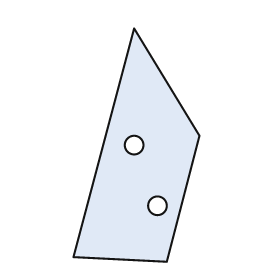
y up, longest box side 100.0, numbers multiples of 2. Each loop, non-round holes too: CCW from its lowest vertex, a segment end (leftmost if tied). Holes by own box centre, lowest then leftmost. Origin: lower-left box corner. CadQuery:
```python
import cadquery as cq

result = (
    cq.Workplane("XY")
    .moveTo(40.0, 0.0)
    .lineTo(54.0, 54.0)
    .lineTo(26.0, 100.0)
    .lineTo(0.0, 2.0)
    .close()
    .moveTo(36.0, 24.0)
    .circle(4.0)
    .moveTo(26.0, 50.0)
    .circle(4.0)
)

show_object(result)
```